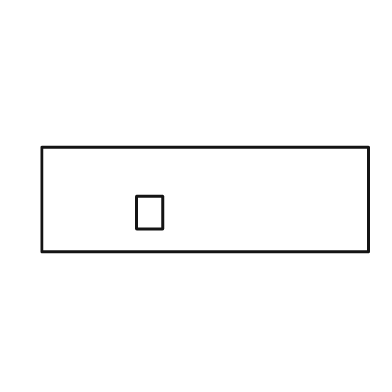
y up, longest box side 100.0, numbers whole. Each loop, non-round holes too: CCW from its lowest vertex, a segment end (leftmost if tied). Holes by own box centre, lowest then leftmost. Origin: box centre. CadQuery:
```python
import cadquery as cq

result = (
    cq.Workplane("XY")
    .moveTo(-50.0, -16.0)
    .lineTo(50.0, -16.0)
    .lineTo(50.0, 16.0)
    .lineTo(-50.0, 16.0)
    .close()
    .moveTo(-21.0, -9.0)
    .lineTo(-13.0, -9.0)
    .lineTo(-13.0, 1.0)
    .lineTo(-21.0, 1.0)
    .close()
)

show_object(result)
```